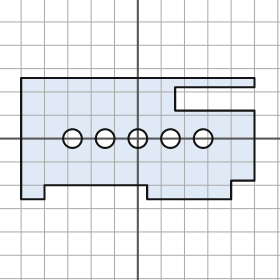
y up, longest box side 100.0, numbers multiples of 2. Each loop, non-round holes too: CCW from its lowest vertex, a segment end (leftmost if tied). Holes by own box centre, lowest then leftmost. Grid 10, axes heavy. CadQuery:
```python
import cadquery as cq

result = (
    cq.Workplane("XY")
    .moveTo(-50.0, -26.0)
    .lineTo(-40.0, -26.0)
    .lineTo(-40.0, -20.0)
    .lineTo(4.0, -20.0)
    .lineTo(4.0, -26.0)
    .lineTo(40.0, -26.0)
    .lineTo(40.0, -18.0)
    .lineTo(50.0, -18.0)
    .lineTo(50.0, 12.0)
    .lineTo(16.0, 12.0)
    .lineTo(16.0, 22.0)
    .lineTo(50.0, 22.0)
    .lineTo(50.0, 26.0)
    .lineTo(-50.0, 26.0)
    .close()
    .moveTo(-28.0, 0.0)
    .circle(4.0)
    .moveTo(-14.0, 0.0)
    .circle(4.0)
    .moveTo(0.0, 0.0)
    .circle(4.0)
    .moveTo(14.0, 0.0)
    .circle(4.0)
    .moveTo(28.0, 0.0)
    .circle(4.0)
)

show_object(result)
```